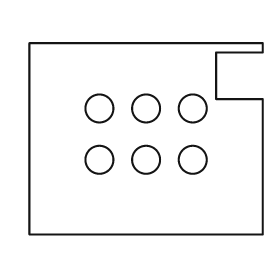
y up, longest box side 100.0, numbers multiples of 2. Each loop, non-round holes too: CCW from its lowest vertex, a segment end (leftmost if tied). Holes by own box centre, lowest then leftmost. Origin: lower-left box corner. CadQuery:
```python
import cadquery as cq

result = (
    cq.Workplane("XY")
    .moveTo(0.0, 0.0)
    .lineTo(100.0, 0.0)
    .lineTo(100.0, 58.0)
    .lineTo(80.0, 58.0)
    .lineTo(80.0, 78.0)
    .lineTo(100.0, 78.0)
    .lineTo(100.0, 82.0)
    .lineTo(0.0, 82.0)
    .close()
    .moveTo(30.0, 32.0)
    .circle(6.0)
    .moveTo(50.0, 32.0)
    .circle(6.0)
    .moveTo(70.0, 32.0)
    .circle(6.0)
    .moveTo(30.0, 54.0)
    .circle(6.0)
    .moveTo(50.0, 54.0)
    .circle(6.0)
    .moveTo(70.0, 54.0)
    .circle(6.0)
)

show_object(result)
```